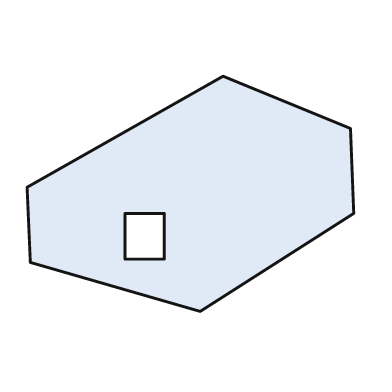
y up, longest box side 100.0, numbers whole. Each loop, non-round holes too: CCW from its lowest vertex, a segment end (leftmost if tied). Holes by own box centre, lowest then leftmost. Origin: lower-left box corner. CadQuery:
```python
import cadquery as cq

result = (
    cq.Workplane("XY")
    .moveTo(53.0, 0.0)
    .lineTo(100.0, 30.0)
    .lineTo(99.0, 56.0)
    .lineTo(60.0, 72.0)
    .lineTo(0.0, 38.0)
    .lineTo(1.0, 15.0)
    .close()
    .moveTo(30.0, 16.0)
    .lineTo(42.0, 16.0)
    .lineTo(42.0, 30.0)
    .lineTo(30.0, 30.0)
    .close()
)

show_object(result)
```